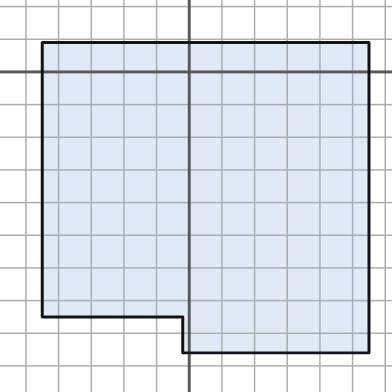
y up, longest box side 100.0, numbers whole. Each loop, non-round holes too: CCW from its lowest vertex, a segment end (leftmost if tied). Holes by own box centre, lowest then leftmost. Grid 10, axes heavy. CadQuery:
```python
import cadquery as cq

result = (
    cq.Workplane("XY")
    .moveTo(-2.0, -86.0)
    .lineTo(55.0, -86.0)
    .lineTo(55.0, 9.0)
    .lineTo(-45.0, 9.0)
    .lineTo(-45.0, -75.0)
    .lineTo(-2.0, -75.0)
    .close()
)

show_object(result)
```